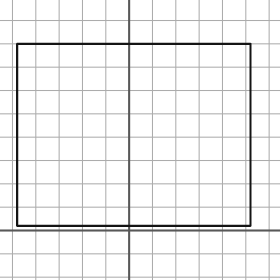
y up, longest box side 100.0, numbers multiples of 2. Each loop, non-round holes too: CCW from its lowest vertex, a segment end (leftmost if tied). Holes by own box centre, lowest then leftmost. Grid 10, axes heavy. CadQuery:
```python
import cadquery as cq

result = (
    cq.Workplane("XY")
    .moveTo(-48.0, 2.0)
    .lineTo(52.0, 2.0)
    .lineTo(52.0, 80.0)
    .lineTo(-48.0, 80.0)
    .close()
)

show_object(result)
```